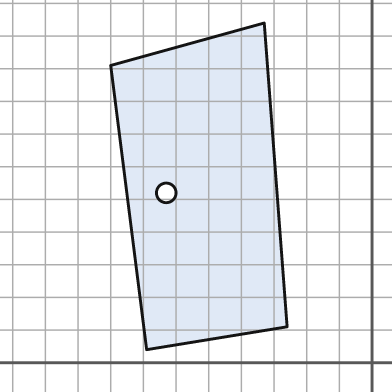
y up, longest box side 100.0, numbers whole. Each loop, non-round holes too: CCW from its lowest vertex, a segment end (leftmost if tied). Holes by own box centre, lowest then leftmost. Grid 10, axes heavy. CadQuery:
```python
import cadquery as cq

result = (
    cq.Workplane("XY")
    .moveTo(-69.0, 4.0)
    .lineTo(-26.0, 11.0)
    .lineTo(-33.0, 104.0)
    .lineTo(-80.0, 91.0)
    .close()
    .moveTo(-63.0, 52.0)
    .circle(3.0)
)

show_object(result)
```